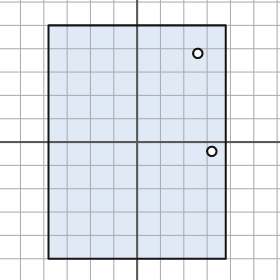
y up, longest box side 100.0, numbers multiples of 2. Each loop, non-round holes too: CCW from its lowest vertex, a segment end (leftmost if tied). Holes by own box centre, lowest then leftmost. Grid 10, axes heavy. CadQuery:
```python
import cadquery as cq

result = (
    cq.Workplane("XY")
    .moveTo(-38.0, -50.0)
    .lineTo(38.0, -50.0)
    .lineTo(38.0, 50.0)
    .lineTo(-38.0, 50.0)
    .close()
    .moveTo(32.0, -4.0)
    .circle(2.0)
    .moveTo(26.0, 38.0)
    .circle(2.0)
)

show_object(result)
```